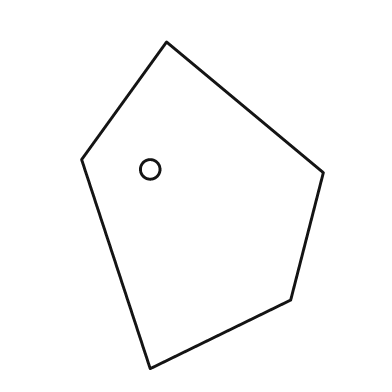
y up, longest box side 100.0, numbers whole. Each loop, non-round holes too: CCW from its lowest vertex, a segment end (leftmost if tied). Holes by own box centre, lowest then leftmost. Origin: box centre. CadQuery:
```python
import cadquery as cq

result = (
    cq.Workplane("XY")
    .moveTo(-16.0, -50.0)
    .lineTo(27.0, -29.0)
    .lineTo(37.0, 10.0)
    .lineTo(-11.0, 50.0)
    .lineTo(-37.0, 14.0)
    .close()
    .moveTo(-16.0, 11.0)
    .circle(3.0)
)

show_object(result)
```